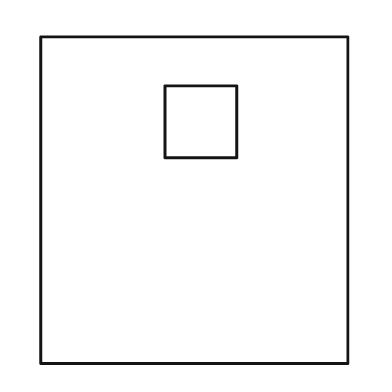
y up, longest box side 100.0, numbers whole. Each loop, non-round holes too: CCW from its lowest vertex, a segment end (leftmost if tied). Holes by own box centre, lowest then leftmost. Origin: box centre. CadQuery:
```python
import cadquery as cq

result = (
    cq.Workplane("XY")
    .moveTo(-47.0, -50.0)
    .lineTo(47.0, -50.0)
    .lineTo(47.0, 50.0)
    .lineTo(-47.0, 50.0)
    .close()
    .moveTo(-9.0, 13.0)
    .lineTo(13.0, 13.0)
    .lineTo(13.0, 35.0)
    .lineTo(-9.0, 35.0)
    .close()
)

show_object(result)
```